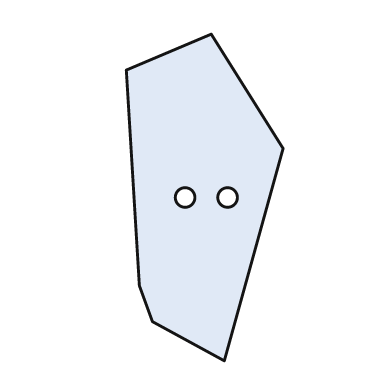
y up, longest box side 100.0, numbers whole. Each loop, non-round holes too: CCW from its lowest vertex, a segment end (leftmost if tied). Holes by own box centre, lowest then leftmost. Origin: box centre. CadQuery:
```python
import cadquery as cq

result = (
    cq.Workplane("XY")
    .moveTo(6.0, -50.0)
    .lineTo(24.0, 15.0)
    .lineTo(2.0, 50.0)
    .lineTo(-24.0, 39.0)
    .lineTo(-20.0, -27.0)
    .lineTo(-16.0, -38.0)
    .close()
    .moveTo(-6.0, 0.0)
    .circle(3.0)
    .moveTo(7.0, 0.0)
    .circle(3.0)
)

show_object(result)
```